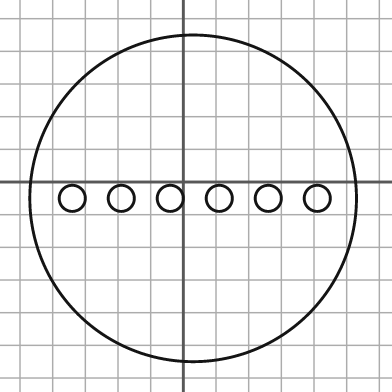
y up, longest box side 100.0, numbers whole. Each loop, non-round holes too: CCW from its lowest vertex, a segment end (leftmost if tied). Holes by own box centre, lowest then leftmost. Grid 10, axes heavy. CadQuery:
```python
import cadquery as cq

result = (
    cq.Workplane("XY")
    .moveTo(3.0, -5.0)
    .circle(50.0)
    .moveTo(-34.0, -5.0)
    .circle(4.0)
    .moveTo(-19.0, -5.0)
    .circle(4.0)
    .moveTo(-4.0, -5.0)
    .circle(4.0)
    .moveTo(11.0, -5.0)
    .circle(4.0)
    .moveTo(26.0, -5.0)
    .circle(4.0)
    .moveTo(41.0, -5.0)
    .circle(4.0)
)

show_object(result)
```